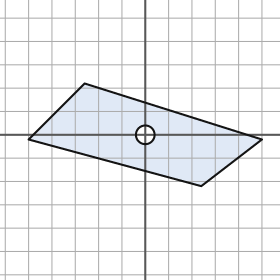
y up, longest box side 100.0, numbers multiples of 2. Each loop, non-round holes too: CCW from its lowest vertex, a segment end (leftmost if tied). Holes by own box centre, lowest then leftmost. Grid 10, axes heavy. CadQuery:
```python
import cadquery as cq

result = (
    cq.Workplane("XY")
    .moveTo(24.0, -22.0)
    .lineTo(50.0, -2.0)
    .lineTo(-26.0, 22.0)
    .lineTo(-50.0, -2.0)
    .close()
    .moveTo(0.0, 0.0)
    .circle(4.0)
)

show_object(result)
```